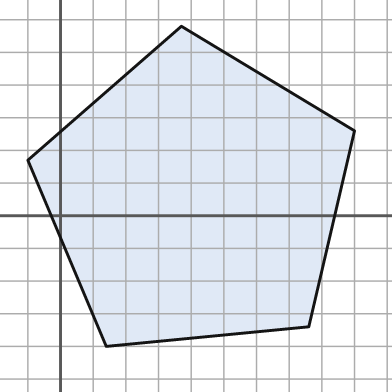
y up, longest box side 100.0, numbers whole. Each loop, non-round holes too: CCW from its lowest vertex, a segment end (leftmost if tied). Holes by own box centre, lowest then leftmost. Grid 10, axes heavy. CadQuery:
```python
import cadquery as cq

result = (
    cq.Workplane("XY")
    .moveTo(14.0, -40.0)
    .lineTo(76.0, -34.0)
    .lineTo(90.0, 26.0)
    .lineTo(37.0, 58.0)
    .lineTo(-10.0, 17.0)
    .close()
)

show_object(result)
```